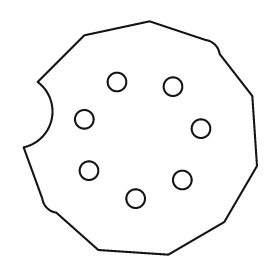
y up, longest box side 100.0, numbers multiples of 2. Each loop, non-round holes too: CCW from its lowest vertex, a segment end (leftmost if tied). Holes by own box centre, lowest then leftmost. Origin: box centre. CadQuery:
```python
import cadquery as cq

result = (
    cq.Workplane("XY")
    .moveTo(12.0, -50.0)
    .lineTo(36.0, -36.0)
    .lineTo(50.0, -12.0)
    .lineTo(48.0, 18.0)
    .lineTo(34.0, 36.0)
    .threePointArc((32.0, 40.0), (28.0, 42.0))
    .lineTo(4.0, 50.0)
    .lineTo(-24.0, 44.0)
    .lineTo(-44.0, 24.0)
    .threePointArc((-38.0, 8.0), (-50.0, -4.0))
    .lineTo(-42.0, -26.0)
    .threePointArc((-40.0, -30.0), (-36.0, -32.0))
    .lineTo(-18.0, -48.0)
    .close()
    .moveTo(-2.0, -26.0)
    .circle(4.0)
    .moveTo(18.0, -18.0)
    .circle(4.0)
    .moveTo(-22.0, -14.0)
    .circle(4.0)
    .moveTo(26.0, 4.0)
    .circle(4.0)
    .moveTo(-24.0, 8.0)
    .circle(4.0)
    .moveTo(14.0, 22.0)
    .circle(4.0)
    .moveTo(-10.0, 24.0)
    .circle(4.0)
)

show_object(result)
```